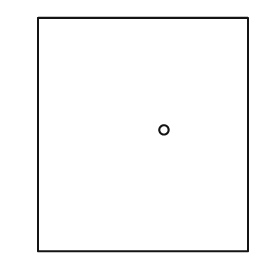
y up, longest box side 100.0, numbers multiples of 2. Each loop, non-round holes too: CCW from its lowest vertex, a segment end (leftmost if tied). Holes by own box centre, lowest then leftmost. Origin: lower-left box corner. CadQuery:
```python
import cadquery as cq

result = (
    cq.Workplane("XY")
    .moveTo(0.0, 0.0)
    .lineTo(90.0, 0.0)
    .lineTo(90.0, 100.0)
    .lineTo(0.0, 100.0)
    .close()
    .moveTo(54.0, 52.0)
    .circle(2.0)
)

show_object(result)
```